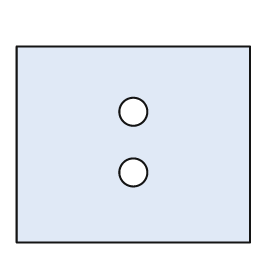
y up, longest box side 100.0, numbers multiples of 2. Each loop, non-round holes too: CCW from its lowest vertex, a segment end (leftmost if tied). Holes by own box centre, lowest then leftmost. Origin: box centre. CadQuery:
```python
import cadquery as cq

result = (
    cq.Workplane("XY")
    .moveTo(-50.0, -42.0)
    .lineTo(50.0, -42.0)
    .lineTo(50.0, 42.0)
    .lineTo(-50.0, 42.0)
    .close()
    .moveTo(0.0, -12.0)
    .circle(6.0)
    .moveTo(0.0, 14.0)
    .circle(6.0)
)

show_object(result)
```